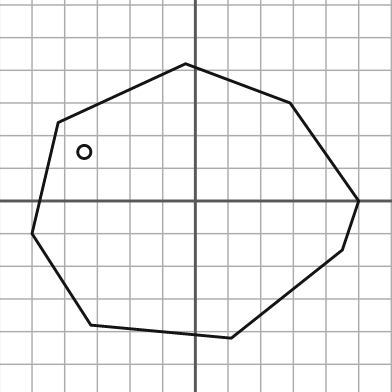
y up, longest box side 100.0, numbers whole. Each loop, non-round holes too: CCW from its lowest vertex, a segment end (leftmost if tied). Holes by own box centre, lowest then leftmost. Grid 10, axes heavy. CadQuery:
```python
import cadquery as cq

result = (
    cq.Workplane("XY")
    .moveTo(11.0, -42.0)
    .lineTo(45.0, -15.0)
    .lineTo(50.0, 0.0)
    .lineTo(29.0, 30.0)
    .lineTo(-3.0, 42.0)
    .lineTo(-42.0, 24.0)
    .lineTo(-50.0, -10.0)
    .lineTo(-32.0, -38.0)
    .close()
    .moveTo(-34.0, 15.0)
    .circle(2.0)
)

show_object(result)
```